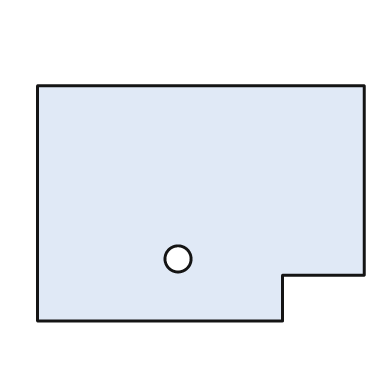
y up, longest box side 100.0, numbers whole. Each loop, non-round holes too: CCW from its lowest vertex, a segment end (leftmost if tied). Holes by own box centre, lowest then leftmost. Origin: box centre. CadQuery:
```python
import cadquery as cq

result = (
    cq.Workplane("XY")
    .moveTo(-50.0, -36.0)
    .lineTo(25.0, -36.0)
    .lineTo(25.0, -22.0)
    .lineTo(50.0, -22.0)
    .lineTo(50.0, 36.0)
    .lineTo(-50.0, 36.0)
    .close()
    .moveTo(-7.0, -17.0)
    .circle(4.0)
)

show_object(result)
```